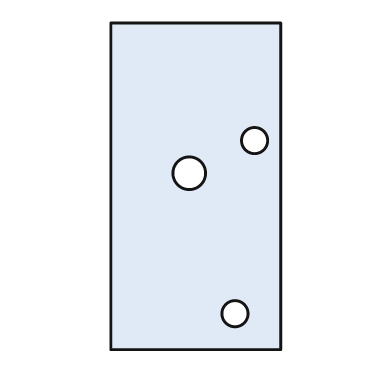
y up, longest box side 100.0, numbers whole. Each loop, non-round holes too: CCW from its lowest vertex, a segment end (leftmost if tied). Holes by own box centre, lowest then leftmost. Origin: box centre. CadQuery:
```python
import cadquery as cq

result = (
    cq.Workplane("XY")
    .moveTo(-26.0, -50.0)
    .lineTo(26.0, -50.0)
    .lineTo(26.0, 50.0)
    .lineTo(-26.0, 50.0)
    .close()
    .moveTo(12.0, -39.0)
    .circle(4.0)
    .moveTo(-2.0, 4.0)
    .circle(5.0)
    .moveTo(18.0, 14.0)
    .circle(4.0)
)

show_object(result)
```